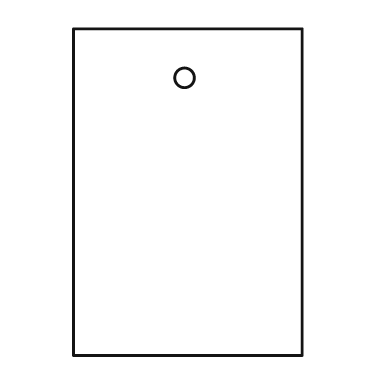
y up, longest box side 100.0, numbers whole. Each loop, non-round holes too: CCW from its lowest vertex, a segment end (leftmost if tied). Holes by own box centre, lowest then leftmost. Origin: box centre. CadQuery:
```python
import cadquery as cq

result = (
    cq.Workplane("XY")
    .moveTo(-35.0, -50.0)
    .lineTo(35.0, -50.0)
    .lineTo(35.0, 50.0)
    .lineTo(-35.0, 50.0)
    .close()
    .moveTo(-1.0, 35.0)
    .circle(3.0)
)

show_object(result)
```